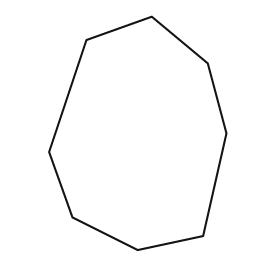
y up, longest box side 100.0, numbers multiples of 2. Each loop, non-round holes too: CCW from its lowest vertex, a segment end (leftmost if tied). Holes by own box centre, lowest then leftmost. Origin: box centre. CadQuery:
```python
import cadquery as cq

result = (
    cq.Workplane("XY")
    .moveTo(0.0, -50.0)
    .lineTo(28.0, -44.0)
    .lineTo(38.0, 0.0)
    .lineTo(30.0, 30.0)
    .lineTo(6.0, 50.0)
    .lineTo(-22.0, 40.0)
    .lineTo(-38.0, -8.0)
    .lineTo(-28.0, -36.0)
    .close()
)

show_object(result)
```